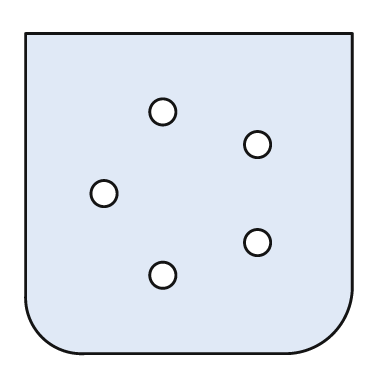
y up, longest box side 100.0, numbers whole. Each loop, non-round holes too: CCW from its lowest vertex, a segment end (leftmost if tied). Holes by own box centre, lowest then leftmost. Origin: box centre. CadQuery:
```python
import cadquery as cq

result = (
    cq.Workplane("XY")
    .moveTo(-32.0, -49.0)
    .lineTo(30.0, -49.0)
    .threePointArc((44.0, -43.0), (50.0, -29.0))
    .lineTo(50.0, 49.0)
    .lineTo(-50.0, 49.0)
    .lineTo(-50.0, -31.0)
    .threePointArc((-45.0, -44.0), (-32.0, -49.0))
    .close()
    .moveTo(-8.0, -25.0)
    .circle(4.0)
    .moveTo(21.0, -15.0)
    .circle(4.0)
    .moveTo(-26.0, 0.0)
    .circle(4.0)
    .moveTo(21.0, 15.0)
    .circle(4.0)
    .moveTo(-8.0, 25.0)
    .circle(4.0)
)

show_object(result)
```